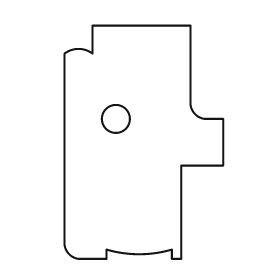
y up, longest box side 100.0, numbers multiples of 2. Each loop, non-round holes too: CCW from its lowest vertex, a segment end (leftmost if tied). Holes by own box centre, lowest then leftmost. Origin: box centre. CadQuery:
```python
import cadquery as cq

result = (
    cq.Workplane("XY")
    .moveTo(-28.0, -50.0)
    .lineTo(-16.0, -50.0)
    .lineTo(-16.0, -46.0)
    .threePointArc((-2.0, -48.0), (12.0, -46.0))
    .lineTo(12.0, -50.0)
    .lineTo(16.0, -50.0)
    .lineTo(16.0, -10.0)
    .lineTo(34.0, -10.0)
    .lineTo(34.0, 10.0)
    .lineTo(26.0, 10.0)
    .threePointArc((22.0, 12.0), (20.0, 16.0))
    .lineTo(20.0, 50.0)
    .lineTo(-22.0, 50.0)
    .lineTo(-22.0, 38.0)
    .threePointArc((-28.0, 40.0), (-34.0, 38.0))
    .lineTo(-34.0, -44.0)
    .threePointArc((-32.0, -48.0), (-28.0, -50.0))
    .close()
    .moveTo(-12.0, 10.0)
    .circle(6.0)
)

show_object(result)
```